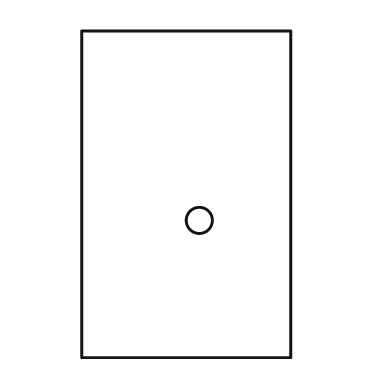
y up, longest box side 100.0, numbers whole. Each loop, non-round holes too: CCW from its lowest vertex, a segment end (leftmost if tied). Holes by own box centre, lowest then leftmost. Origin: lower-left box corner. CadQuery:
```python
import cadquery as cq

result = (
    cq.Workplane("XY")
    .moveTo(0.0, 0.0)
    .lineTo(64.0, 0.0)
    .lineTo(64.0, 100.0)
    .lineTo(0.0, 100.0)
    .close()
    .moveTo(36.0, 42.0)
    .circle(4.0)
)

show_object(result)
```